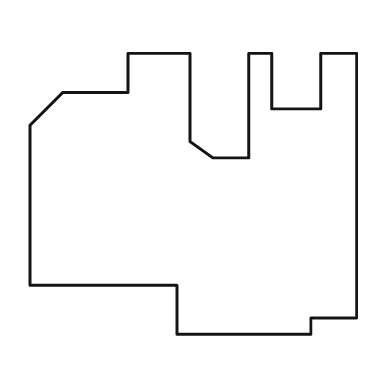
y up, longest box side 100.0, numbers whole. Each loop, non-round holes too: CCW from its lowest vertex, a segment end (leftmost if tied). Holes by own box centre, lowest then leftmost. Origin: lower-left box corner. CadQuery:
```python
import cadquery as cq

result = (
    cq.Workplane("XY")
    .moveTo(45.0, 0.0)
    .lineTo(86.0, 0.0)
    .lineTo(86.0, 5.0)
    .lineTo(100.0, 5.0)
    .lineTo(100.0, 86.0)
    .lineTo(89.0, 86.0)
    .lineTo(89.0, 69.0)
    .lineTo(74.0, 69.0)
    .lineTo(74.0, 86.0)
    .lineTo(67.0, 86.0)
    .lineTo(67.0, 54.0)
    .lineTo(56.0, 54.0)
    .lineTo(49.0, 59.0)
    .lineTo(49.0, 86.0)
    .lineTo(30.0, 86.0)
    .lineTo(30.0, 74.0)
    .lineTo(10.0, 74.0)
    .lineTo(0.0, 64.0)
    .lineTo(0.0, 15.0)
    .lineTo(45.0, 15.0)
    .close()
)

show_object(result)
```